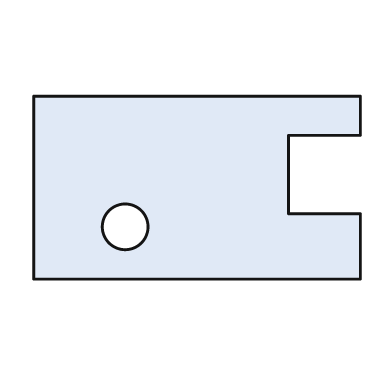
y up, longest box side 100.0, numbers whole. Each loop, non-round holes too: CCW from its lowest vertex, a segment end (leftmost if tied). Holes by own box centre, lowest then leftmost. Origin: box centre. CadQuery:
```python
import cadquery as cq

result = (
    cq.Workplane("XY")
    .moveTo(-50.0, -28.0)
    .lineTo(50.0, -28.0)
    .lineTo(50.0, -8.0)
    .lineTo(28.0, -8.0)
    .lineTo(28.0, 16.0)
    .lineTo(50.0, 16.0)
    .lineTo(50.0, 28.0)
    .lineTo(-50.0, 28.0)
    .close()
    .moveTo(-22.0, -12.0)
    .circle(7.0)
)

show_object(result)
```